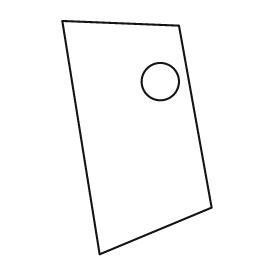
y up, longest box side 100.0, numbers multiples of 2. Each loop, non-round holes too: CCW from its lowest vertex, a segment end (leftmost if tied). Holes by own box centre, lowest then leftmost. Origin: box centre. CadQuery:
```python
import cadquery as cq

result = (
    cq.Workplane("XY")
    .moveTo(-16.0, -50.0)
    .lineTo(32.0, -30.0)
    .lineTo(18.0, 48.0)
    .lineTo(-32.0, 50.0)
    .close()
    .moveTo(10.0, 24.0)
    .circle(8.0)
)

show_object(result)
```